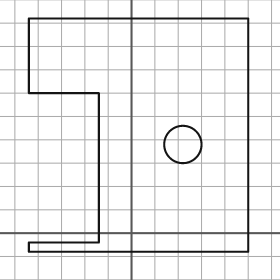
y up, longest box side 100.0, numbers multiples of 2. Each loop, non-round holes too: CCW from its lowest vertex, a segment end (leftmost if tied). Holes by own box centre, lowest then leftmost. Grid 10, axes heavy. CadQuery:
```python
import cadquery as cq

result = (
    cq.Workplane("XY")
    .moveTo(-44.0, -8.0)
    .lineTo(50.0, -8.0)
    .lineTo(50.0, 92.0)
    .lineTo(-44.0, 92.0)
    .lineTo(-44.0, 60.0)
    .lineTo(-14.0, 60.0)
    .lineTo(-14.0, -4.0)
    .lineTo(-44.0, -4.0)
    .close()
    .moveTo(22.0, 38.0)
    .circle(8.0)
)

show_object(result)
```